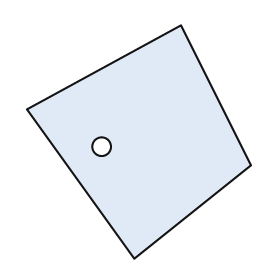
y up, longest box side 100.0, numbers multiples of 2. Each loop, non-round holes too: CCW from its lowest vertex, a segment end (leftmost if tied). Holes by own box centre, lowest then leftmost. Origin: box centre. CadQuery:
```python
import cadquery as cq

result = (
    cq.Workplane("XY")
    .moveTo(-2.0, -50.0)
    .lineTo(48.0, -10.0)
    .lineTo(18.0, 50.0)
    .lineTo(-48.0, 14.0)
    .close()
    .moveTo(-16.0, -2.0)
    .circle(4.0)
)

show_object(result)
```